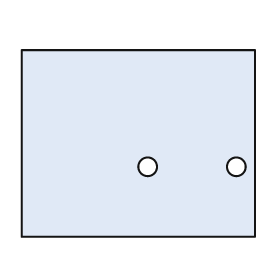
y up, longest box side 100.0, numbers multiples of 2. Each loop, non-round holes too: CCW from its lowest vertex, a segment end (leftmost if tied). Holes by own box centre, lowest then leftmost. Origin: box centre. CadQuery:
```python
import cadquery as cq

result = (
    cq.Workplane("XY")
    .moveTo(-50.0, -40.0)
    .lineTo(50.0, -40.0)
    .lineTo(50.0, 40.0)
    .lineTo(-50.0, 40.0)
    .close()
    .moveTo(4.0, -10.0)
    .circle(4.0)
    .moveTo(42.0, -10.0)
    .circle(4.0)
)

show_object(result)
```